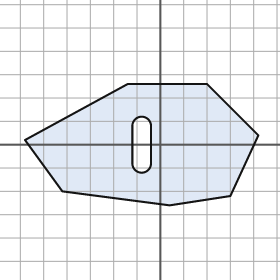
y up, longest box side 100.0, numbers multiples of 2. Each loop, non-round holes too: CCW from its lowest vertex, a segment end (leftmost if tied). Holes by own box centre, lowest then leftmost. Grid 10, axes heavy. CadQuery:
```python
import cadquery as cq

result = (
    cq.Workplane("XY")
    .moveTo(4.0, -26.0)
    .lineTo(30.0, -22.0)
    .lineTo(42.0, 4.0)
    .lineTo(20.0, 26.0)
    .lineTo(-14.0, 26.0)
    .lineTo(-58.0, 2.0)
    .lineTo(-42.0, -20.0)
    .close()
    .moveTo(-12.0, -8.0)
    .threePointArc((-8.0, -12.0), (-4.0, -8.0))
    .lineTo(-4.0, 8.0)
    .threePointArc((-8.0, 12.0), (-12.0, 8.0))
    .close()
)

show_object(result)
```